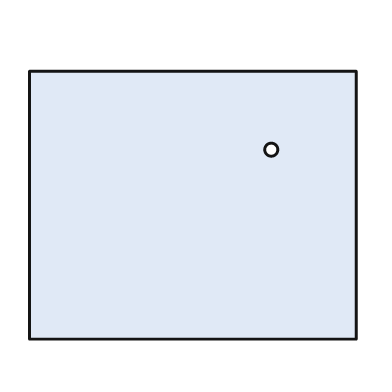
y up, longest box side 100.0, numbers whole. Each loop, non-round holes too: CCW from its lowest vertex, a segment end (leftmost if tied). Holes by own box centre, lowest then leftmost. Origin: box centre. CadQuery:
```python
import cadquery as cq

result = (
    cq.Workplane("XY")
    .moveTo(-50.0, -41.0)
    .lineTo(50.0, -41.0)
    .lineTo(50.0, 41.0)
    .lineTo(-50.0, 41.0)
    .close()
    .moveTo(24.0, 17.0)
    .circle(2.0)
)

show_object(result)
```